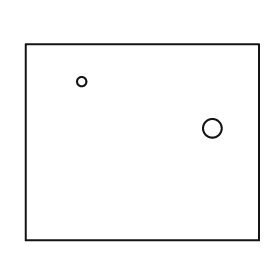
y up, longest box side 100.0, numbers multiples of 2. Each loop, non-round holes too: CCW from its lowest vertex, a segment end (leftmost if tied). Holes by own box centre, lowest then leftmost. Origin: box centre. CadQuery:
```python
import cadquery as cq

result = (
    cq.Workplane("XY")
    .moveTo(-50.0, -42.0)
    .lineTo(50.0, -42.0)
    .lineTo(50.0, 42.0)
    .lineTo(-50.0, 42.0)
    .close()
    .moveTo(30.0, 6.0)
    .circle(4.0)
    .moveTo(-26.0, 26.0)
    .circle(2.0)
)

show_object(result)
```